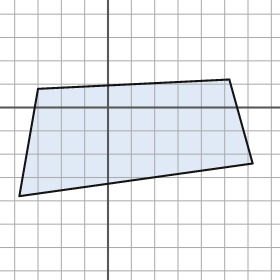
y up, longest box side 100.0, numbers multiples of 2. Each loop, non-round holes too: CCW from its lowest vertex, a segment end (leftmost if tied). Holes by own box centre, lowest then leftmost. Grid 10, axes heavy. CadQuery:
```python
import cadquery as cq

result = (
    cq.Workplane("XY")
    .moveTo(-38.0, -38.0)
    .lineTo(62.0, -24.0)
    .lineTo(52.0, 12.0)
    .lineTo(-30.0, 8.0)
    .close()
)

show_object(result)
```